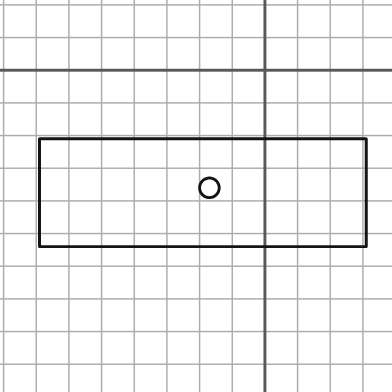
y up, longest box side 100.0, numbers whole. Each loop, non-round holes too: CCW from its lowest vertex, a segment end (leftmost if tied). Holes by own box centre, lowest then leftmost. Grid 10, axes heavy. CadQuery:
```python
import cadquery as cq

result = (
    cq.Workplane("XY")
    .moveTo(-69.0, -54.0)
    .lineTo(31.0, -54.0)
    .lineTo(31.0, -21.0)
    .lineTo(-69.0, -21.0)
    .close()
    .moveTo(-17.0, -36.0)
    .circle(3.0)
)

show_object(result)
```